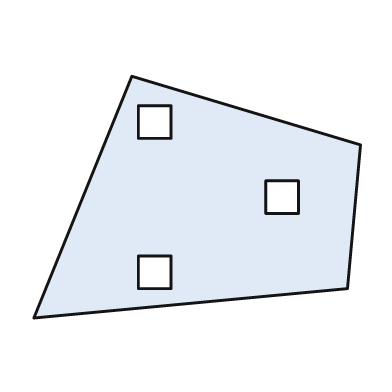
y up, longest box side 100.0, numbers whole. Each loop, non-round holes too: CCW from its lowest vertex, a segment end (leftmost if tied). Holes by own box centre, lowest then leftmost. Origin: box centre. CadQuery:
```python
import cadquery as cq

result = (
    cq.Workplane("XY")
    .moveTo(-50.0, -37.0)
    .lineTo(46.0, -28.0)
    .lineTo(50.0, 16.0)
    .lineTo(-20.0, 37.0)
    .close()
    .moveTo(-18.0, -28.0)
    .lineTo(-8.0, -28.0)
    .lineTo(-8.0, -18.0)
    .lineTo(-18.0, -18.0)
    .close()
    .moveTo(21.0, -5.0)
    .lineTo(31.0, -5.0)
    .lineTo(31.0, 5.0)
    .lineTo(21.0, 5.0)
    .close()
    .moveTo(-18.0, 18.0)
    .lineTo(-8.0, 18.0)
    .lineTo(-8.0, 28.0)
    .lineTo(-18.0, 28.0)
    .close()
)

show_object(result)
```